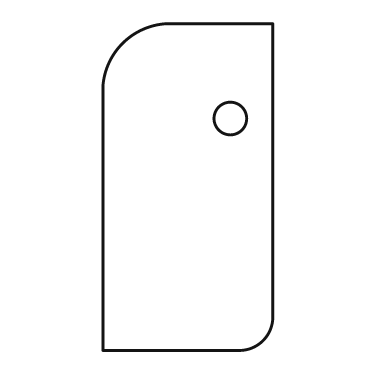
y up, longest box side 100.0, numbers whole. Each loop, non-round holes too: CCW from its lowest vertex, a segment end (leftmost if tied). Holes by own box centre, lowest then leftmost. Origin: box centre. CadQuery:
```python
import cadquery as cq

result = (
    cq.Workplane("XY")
    .moveTo(-26.0, -50.0)
    .lineTo(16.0, -50.0)
    .threePointArc((23.0, -47.0), (26.0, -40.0))
    .lineTo(26.0, 50.0)
    .lineTo(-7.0, 50.0)
    .threePointArc((-20.0, 44.0), (-26.0, 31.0))
    .close()
    .moveTo(13.0, 21.0)
    .circle(5.0)
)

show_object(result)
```